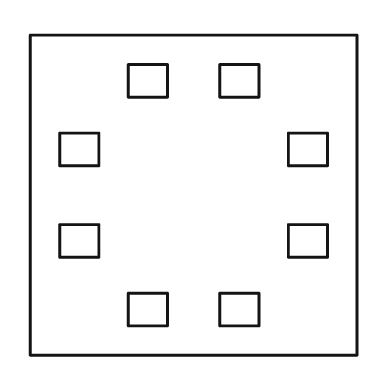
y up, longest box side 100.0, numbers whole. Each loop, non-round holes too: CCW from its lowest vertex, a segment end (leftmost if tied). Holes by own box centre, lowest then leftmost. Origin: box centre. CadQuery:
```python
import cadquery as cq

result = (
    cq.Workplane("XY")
    .moveTo(-50.0, -49.0)
    .lineTo(50.0, -49.0)
    .lineTo(50.0, 49.0)
    .lineTo(-50.0, 49.0)
    .close()
    .moveTo(-20.0, -40.0)
    .lineTo(-8.0, -40.0)
    .lineTo(-8.0, -30.0)
    .lineTo(-20.0, -30.0)
    .close()
    .moveTo(8.0, -40.0)
    .lineTo(20.0, -40.0)
    .lineTo(20.0, -30.0)
    .lineTo(8.0, -30.0)
    .close()
    .moveTo(-41.0, -19.0)
    .lineTo(-29.0, -19.0)
    .lineTo(-29.0, -9.0)
    .lineTo(-41.0, -9.0)
    .close()
    .moveTo(29.0, -19.0)
    .lineTo(41.0, -19.0)
    .lineTo(41.0, -9.0)
    .lineTo(29.0, -9.0)
    .close()
    .moveTo(-41.0, 9.0)
    .lineTo(-29.0, 9.0)
    .lineTo(-29.0, 19.0)
    .lineTo(-41.0, 19.0)
    .close()
    .moveTo(29.0, 9.0)
    .lineTo(41.0, 9.0)
    .lineTo(41.0, 19.0)
    .lineTo(29.0, 19.0)
    .close()
    .moveTo(-20.0, 30.0)
    .lineTo(-8.0, 30.0)
    .lineTo(-8.0, 40.0)
    .lineTo(-20.0, 40.0)
    .close()
    .moveTo(8.0, 30.0)
    .lineTo(20.0, 30.0)
    .lineTo(20.0, 40.0)
    .lineTo(8.0, 40.0)
    .close()
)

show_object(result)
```